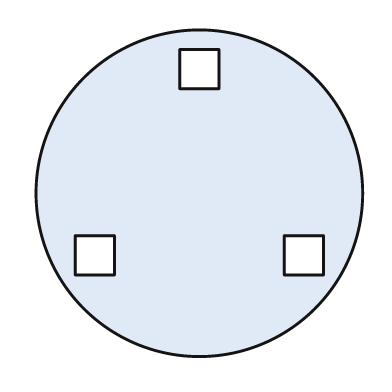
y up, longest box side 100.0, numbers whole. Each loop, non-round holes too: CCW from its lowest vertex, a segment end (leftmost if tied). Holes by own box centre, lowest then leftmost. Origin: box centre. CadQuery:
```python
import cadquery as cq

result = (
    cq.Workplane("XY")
    .moveTo(0.0, 0.0)
    .circle(50.0)
    .moveTo(-38.0, -25.0)
    .lineTo(-26.0, -25.0)
    .lineTo(-26.0, -13.0)
    .lineTo(-38.0, -13.0)
    .close()
    .moveTo(26.0, -25.0)
    .lineTo(38.0, -25.0)
    .lineTo(38.0, -13.0)
    .lineTo(26.0, -13.0)
    .close()
    .moveTo(-6.0, 32.0)
    .lineTo(6.0, 32.0)
    .lineTo(6.0, 44.0)
    .lineTo(-6.0, 44.0)
    .close()
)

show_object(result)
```